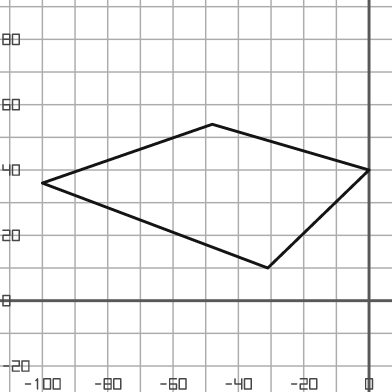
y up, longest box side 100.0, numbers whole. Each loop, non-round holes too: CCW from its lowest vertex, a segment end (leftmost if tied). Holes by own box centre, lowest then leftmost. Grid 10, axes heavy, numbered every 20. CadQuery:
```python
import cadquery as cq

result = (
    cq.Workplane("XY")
    .moveTo(-31.0, 10.0)
    .lineTo(0.0, 40.0)
    .lineTo(-48.0, 54.0)
    .lineTo(-100.0, 36.0)
    .close()
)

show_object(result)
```